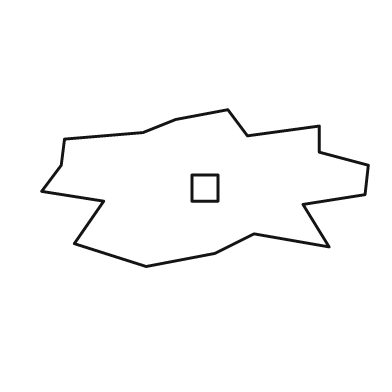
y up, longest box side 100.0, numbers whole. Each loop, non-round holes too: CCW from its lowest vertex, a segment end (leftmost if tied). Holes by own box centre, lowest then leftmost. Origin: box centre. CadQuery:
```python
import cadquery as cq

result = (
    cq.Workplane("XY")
    .moveTo(-18.0, -24.0)
    .lineTo(3.0, -20.0)
    .lineTo(15.0, -14.0)
    .lineTo(38.0, -18.0)
    .lineTo(30.0, -5.0)
    .lineTo(49.0, -2.0)
    .lineTo(50.0, 7.0)
    .lineTo(35.0, 11.0)
    .lineTo(35.0, 19.0)
    .lineTo(13.0, 16.0)
    .lineTo(7.0, 24.0)
    .lineTo(-9.0, 21.0)
    .lineTo(-19.0, 17.0)
    .lineTo(-43.0, 15.0)
    .lineTo(-44.0, 7.0)
    .lineTo(-50.0, -1.0)
    .lineTo(-31.0, -4.0)
    .lineTo(-40.0, -17.0)
    .close()
    .moveTo(-4.0, -4.0)
    .lineTo(4.0, -4.0)
    .lineTo(4.0, 4.0)
    .lineTo(-4.0, 4.0)
    .close()
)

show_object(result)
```